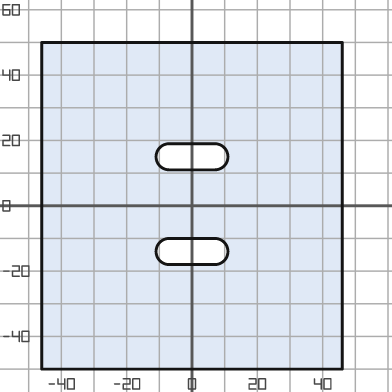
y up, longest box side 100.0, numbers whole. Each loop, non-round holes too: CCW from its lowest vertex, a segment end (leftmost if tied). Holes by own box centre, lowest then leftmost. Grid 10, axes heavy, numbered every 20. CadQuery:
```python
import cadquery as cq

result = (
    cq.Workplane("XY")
    .moveTo(-46.0, -50.0)
    .lineTo(46.0, -50.0)
    .lineTo(46.0, 50.0)
    .lineTo(-46.0, 50.0)
    .close()
    .moveTo(-7.0, -18.0)
    .lineTo(7.0, -18.0)
    .threePointArc((11.0, -14.0), (7.0, -10.0))
    .lineTo(-7.0, -10.0)
    .threePointArc((-11.0, -14.0), (-7.0, -18.0))
    .close()
    .moveTo(-7.0, 11.0)
    .lineTo(7.0, 11.0)
    .threePointArc((11.0, 15.0), (7.0, 19.0))
    .lineTo(-7.0, 19.0)
    .threePointArc((-11.0, 15.0), (-7.0, 11.0))
    .close()
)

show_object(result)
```